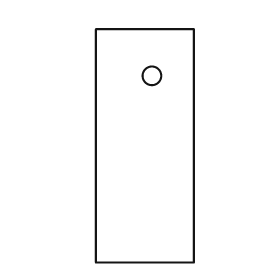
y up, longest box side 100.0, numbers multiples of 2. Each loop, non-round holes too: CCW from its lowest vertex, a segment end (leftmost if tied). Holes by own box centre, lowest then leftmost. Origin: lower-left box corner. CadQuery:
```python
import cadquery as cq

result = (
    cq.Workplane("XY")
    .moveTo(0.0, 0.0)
    .lineTo(42.0, 0.0)
    .lineTo(42.0, 100.0)
    .lineTo(0.0, 100.0)
    .close()
    .moveTo(24.0, 80.0)
    .circle(4.0)
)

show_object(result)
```